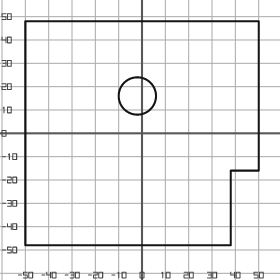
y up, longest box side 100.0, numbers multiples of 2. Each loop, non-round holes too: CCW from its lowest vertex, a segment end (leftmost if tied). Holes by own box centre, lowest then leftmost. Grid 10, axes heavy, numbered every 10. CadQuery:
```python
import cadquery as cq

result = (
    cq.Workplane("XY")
    .moveTo(-50.0, -48.0)
    .lineTo(38.0, -48.0)
    .lineTo(38.0, -16.0)
    .lineTo(50.0, -16.0)
    .lineTo(50.0, 48.0)
    .lineTo(-50.0, 48.0)
    .close()
    .moveTo(-2.0, 16.0)
    .circle(8.0)
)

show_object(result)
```